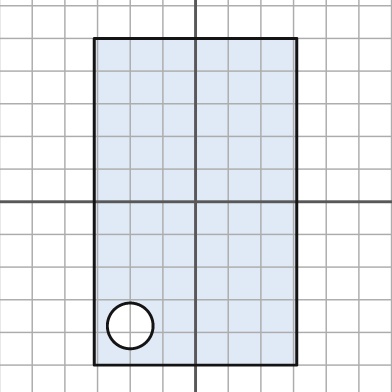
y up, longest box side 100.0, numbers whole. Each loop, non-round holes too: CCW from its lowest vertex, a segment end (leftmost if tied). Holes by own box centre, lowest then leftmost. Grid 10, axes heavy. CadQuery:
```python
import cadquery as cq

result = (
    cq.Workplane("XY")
    .moveTo(-31.0, -50.0)
    .lineTo(31.0, -50.0)
    .lineTo(31.0, 50.0)
    .lineTo(-31.0, 50.0)
    .close()
    .moveTo(-20.0, -38.0)
    .circle(7.0)
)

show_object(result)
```